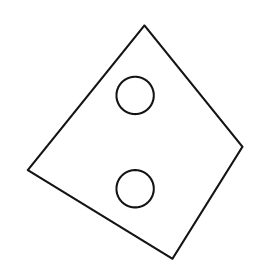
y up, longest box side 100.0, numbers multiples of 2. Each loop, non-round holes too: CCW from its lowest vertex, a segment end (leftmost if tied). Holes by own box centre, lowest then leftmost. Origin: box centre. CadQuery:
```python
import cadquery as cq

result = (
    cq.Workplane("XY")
    .moveTo(16.0, -50.0)
    .lineTo(46.0, -2.0)
    .lineTo(4.0, 50.0)
    .lineTo(-46.0, -12.0)
    .close()
    .moveTo(0.0, -20.0)
    .circle(8.0)
    .moveTo(0.0, 20.0)
    .circle(8.0)
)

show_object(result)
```